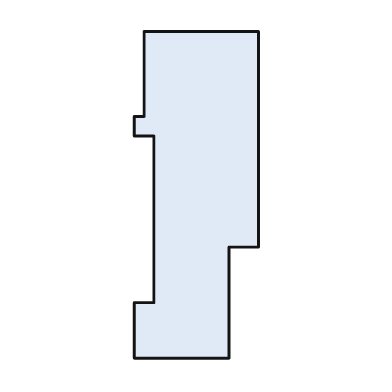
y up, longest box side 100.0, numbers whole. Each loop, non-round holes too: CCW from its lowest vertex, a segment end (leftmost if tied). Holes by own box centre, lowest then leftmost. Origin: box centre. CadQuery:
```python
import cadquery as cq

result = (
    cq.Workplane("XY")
    .moveTo(-19.0, -50.0)
    .lineTo(10.0, -50.0)
    .lineTo(10.0, -16.0)
    .lineTo(19.0, -16.0)
    .lineTo(19.0, 50.0)
    .lineTo(-16.0, 50.0)
    .lineTo(-16.0, 24.0)
    .lineTo(-19.0, 24.0)
    .lineTo(-19.0, 18.0)
    .lineTo(-13.0, 18.0)
    .lineTo(-13.0, -33.0)
    .lineTo(-19.0, -33.0)
    .close()
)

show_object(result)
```